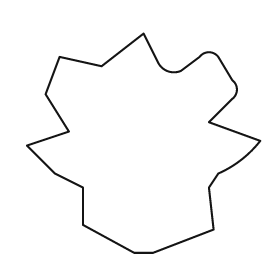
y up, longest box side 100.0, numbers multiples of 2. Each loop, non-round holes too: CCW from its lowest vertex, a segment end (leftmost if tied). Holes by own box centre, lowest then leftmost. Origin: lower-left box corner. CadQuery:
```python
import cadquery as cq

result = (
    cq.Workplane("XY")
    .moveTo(46.0, 0.0)
    .lineTo(54.0, 0.0)
    .lineTo(80.0, 10.0)
    .lineTo(78.0, 28.0)
    .lineTo(82.0, 34.0)
    .threePointArc((92.0, 40.0), (100.0, 48.0))
    .lineTo(78.0, 56.0)
    .lineTo(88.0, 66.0)
    .threePointArc((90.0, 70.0), (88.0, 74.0))
    .lineTo(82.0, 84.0)
    .threePointArc((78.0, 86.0), (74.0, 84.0))
    .lineTo(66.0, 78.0)
    .threePointArc((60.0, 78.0), (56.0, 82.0))
    .lineTo(50.0, 94.0)
    .lineTo(32.0, 80.0)
    .lineTo(14.0, 84.0)
    .lineTo(8.0, 68.0)
    .lineTo(18.0, 52.0)
    .lineTo(0.0, 46.0)
    .lineTo(12.0, 34.0)
    .lineTo(24.0, 28.0)
    .lineTo(24.0, 12.0)
    .close()
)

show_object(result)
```